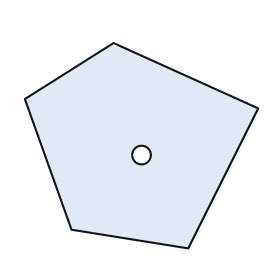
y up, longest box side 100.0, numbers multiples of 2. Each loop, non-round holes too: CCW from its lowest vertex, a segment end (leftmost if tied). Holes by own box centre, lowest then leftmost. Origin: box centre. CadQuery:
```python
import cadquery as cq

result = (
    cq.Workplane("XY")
    .moveTo(20.0, -44.0)
    .lineTo(50.0, 16.0)
    .lineTo(-12.0, 44.0)
    .lineTo(-50.0, 20.0)
    .lineTo(-30.0, -36.0)
    .close()
    .moveTo(0.0, -4.0)
    .circle(4.0)
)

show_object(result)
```